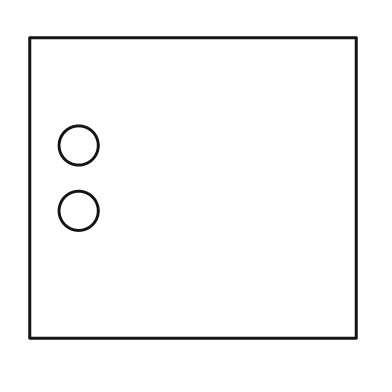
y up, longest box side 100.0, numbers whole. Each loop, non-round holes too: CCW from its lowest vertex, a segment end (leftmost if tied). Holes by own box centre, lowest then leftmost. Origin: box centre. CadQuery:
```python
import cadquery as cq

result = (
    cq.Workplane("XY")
    .moveTo(-50.0, -46.0)
    .lineTo(50.0, -46.0)
    .lineTo(50.0, 46.0)
    .lineTo(-50.0, 46.0)
    .close()
    .moveTo(-35.0, -7.0)
    .circle(6.0)
    .moveTo(-35.0, 13.0)
    .circle(6.0)
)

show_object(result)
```